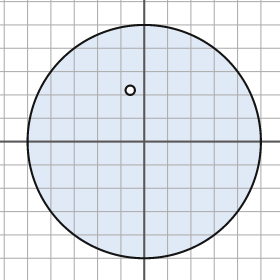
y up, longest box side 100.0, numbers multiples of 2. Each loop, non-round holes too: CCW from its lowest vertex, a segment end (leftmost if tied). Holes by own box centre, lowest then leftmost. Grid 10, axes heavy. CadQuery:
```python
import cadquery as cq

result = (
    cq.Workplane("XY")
    .moveTo(0.0, 0.0)
    .circle(50.0)
    .moveTo(-6.0, 22.0)
    .circle(2.0)
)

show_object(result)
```